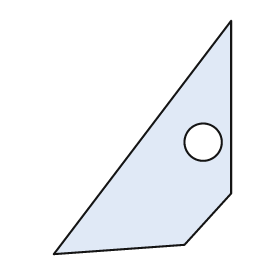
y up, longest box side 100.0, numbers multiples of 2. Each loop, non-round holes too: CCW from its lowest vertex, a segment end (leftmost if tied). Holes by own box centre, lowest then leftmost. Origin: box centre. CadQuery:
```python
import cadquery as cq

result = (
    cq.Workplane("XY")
    .moveTo(-38.0, -50.0)
    .lineTo(18.0, -46.0)
    .lineTo(38.0, -24.0)
    .lineTo(38.0, 50.0)
    .close()
    .moveTo(26.0, -2.0)
    .circle(8.0)
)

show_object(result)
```